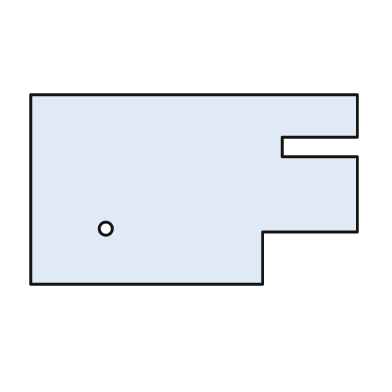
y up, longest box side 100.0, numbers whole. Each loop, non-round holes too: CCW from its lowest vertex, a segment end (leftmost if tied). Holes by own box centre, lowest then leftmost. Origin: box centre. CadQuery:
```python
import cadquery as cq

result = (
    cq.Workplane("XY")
    .moveTo(-50.0, -29.0)
    .lineTo(21.0, -29.0)
    .lineTo(21.0, -13.0)
    .lineTo(50.0, -13.0)
    .lineTo(50.0, 10.0)
    .lineTo(27.0, 10.0)
    .lineTo(27.0, 16.0)
    .lineTo(50.0, 16.0)
    .lineTo(50.0, 29.0)
    .lineTo(-50.0, 29.0)
    .close()
    .moveTo(-27.0, -12.0)
    .circle(2.0)
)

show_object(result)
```